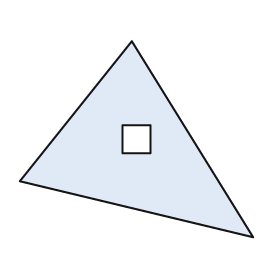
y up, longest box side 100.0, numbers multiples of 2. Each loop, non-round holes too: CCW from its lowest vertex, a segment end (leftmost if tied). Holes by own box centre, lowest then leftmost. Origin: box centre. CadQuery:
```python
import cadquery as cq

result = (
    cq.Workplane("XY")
    .moveTo(50.0, -42.0)
    .lineTo(-2.0, 42.0)
    .lineTo(-50.0, -18.0)
    .close()
    .moveTo(-6.0, -6.0)
    .lineTo(6.0, -6.0)
    .lineTo(6.0, 6.0)
    .lineTo(-6.0, 6.0)
    .close()
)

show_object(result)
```